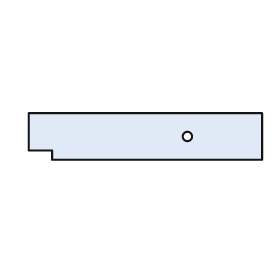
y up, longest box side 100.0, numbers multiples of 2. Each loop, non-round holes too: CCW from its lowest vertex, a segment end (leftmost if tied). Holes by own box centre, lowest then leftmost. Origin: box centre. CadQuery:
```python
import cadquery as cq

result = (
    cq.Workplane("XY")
    .moveTo(-40.0, -10.0)
    .lineTo(50.0, -10.0)
    .lineTo(50.0, 10.0)
    .lineTo(-50.0, 10.0)
    .lineTo(-50.0, -6.0)
    .lineTo(-40.0, -6.0)
    .close()
    .moveTo(18.0, 0.0)
    .circle(2.0)
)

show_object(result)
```